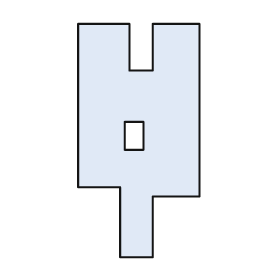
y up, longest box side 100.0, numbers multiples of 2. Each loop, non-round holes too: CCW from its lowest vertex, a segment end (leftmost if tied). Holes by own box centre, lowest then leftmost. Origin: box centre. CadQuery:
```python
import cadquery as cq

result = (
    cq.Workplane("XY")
    .moveTo(-8.0, -50.0)
    .lineTo(6.0, -50.0)
    .lineTo(6.0, -24.0)
    .lineTo(26.0, -24.0)
    .lineTo(26.0, 50.0)
    .lineTo(6.0, 50.0)
    .lineTo(6.0, 30.0)
    .lineTo(-4.0, 30.0)
    .lineTo(-4.0, 50.0)
    .lineTo(-26.0, 50.0)
    .lineTo(-26.0, -20.0)
    .lineTo(-8.0, -20.0)
    .close()
    .moveTo(-6.0, -4.0)
    .lineTo(2.0, -4.0)
    .lineTo(2.0, 8.0)
    .lineTo(-6.0, 8.0)
    .close()
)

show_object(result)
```